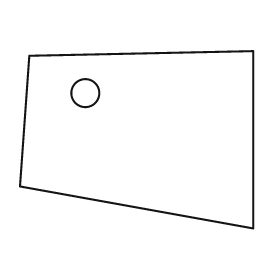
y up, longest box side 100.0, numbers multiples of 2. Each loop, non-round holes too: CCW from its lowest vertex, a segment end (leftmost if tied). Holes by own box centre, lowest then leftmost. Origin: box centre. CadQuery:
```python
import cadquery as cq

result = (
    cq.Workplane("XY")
    .moveTo(50.0, -38.0)
    .lineTo(50.0, 38.0)
    .lineTo(-46.0, 36.0)
    .lineTo(-50.0, -20.0)
    .close()
    .moveTo(-22.0, 20.0)
    .circle(6.0)
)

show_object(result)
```